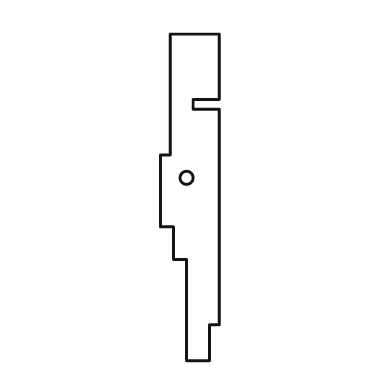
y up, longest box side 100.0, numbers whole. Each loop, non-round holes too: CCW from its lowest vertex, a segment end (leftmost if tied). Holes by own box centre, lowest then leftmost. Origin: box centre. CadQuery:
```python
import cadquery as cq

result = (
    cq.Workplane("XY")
    .moveTo(-1.0, -50.0)
    .lineTo(6.0, -50.0)
    .lineTo(6.0, -39.0)
    .lineTo(9.0, -39.0)
    .lineTo(9.0, 27.0)
    .lineTo(1.0, 27.0)
    .lineTo(1.0, 30.0)
    .lineTo(9.0, 30.0)
    .lineTo(9.0, 50.0)
    .lineTo(-6.0, 50.0)
    .lineTo(-6.0, 13.0)
    .lineTo(-9.0, 13.0)
    .lineTo(-9.0, -9.0)
    .lineTo(-5.0, -9.0)
    .lineTo(-5.0, -19.0)
    .lineTo(-1.0, -19.0)
    .close()
    .moveTo(-1.0, 6.0)
    .circle(2.0)
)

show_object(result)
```